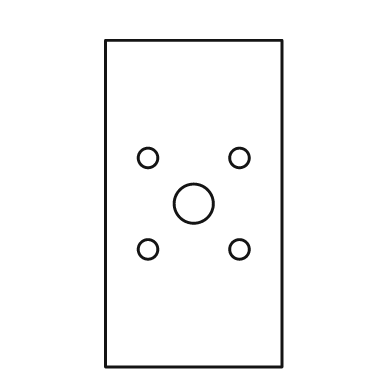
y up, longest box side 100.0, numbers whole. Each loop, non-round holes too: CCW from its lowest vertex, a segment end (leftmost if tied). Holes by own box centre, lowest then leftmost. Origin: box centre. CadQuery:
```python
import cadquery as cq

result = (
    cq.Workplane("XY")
    .moveTo(-27.0, -50.0)
    .lineTo(27.0, -50.0)
    .lineTo(27.0, 50.0)
    .lineTo(-27.0, 50.0)
    .close()
    .moveTo(-14.0, -14.0)
    .circle(3.0)
    .moveTo(14.0, -14.0)
    .circle(3.0)
    .moveTo(0.0, 0.0)
    .circle(6.0)
    .moveTo(-14.0, 14.0)
    .circle(3.0)
    .moveTo(14.0, 14.0)
    .circle(3.0)
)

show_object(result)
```